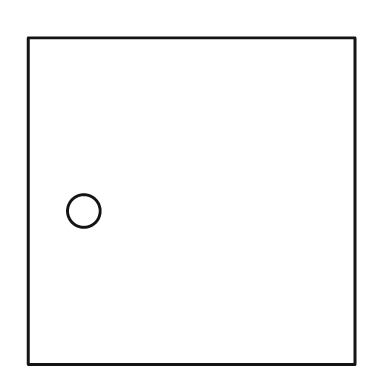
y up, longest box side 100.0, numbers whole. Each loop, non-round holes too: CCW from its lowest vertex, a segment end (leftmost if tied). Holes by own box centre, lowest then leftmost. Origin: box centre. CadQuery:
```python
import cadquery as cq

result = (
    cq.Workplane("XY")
    .moveTo(-50.0, -50.0)
    .lineTo(50.0, -50.0)
    .lineTo(50.0, 50.0)
    .lineTo(-50.0, 50.0)
    .close()
    .moveTo(-33.0, -3.0)
    .circle(5.0)
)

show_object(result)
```